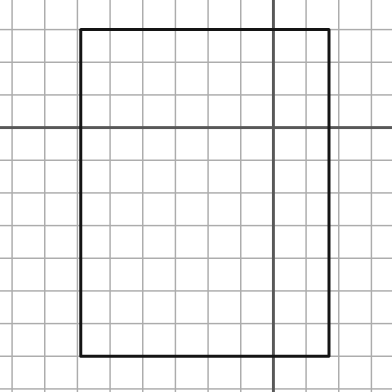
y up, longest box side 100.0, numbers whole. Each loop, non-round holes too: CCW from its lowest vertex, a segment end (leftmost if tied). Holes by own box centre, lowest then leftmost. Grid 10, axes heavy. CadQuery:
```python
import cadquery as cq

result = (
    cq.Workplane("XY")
    .moveTo(-59.0, -70.0)
    .lineTo(17.0, -70.0)
    .lineTo(17.0, 30.0)
    .lineTo(-59.0, 30.0)
    .close()
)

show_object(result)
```